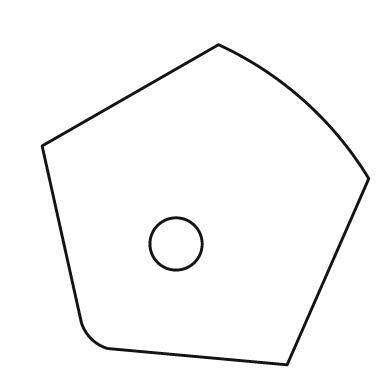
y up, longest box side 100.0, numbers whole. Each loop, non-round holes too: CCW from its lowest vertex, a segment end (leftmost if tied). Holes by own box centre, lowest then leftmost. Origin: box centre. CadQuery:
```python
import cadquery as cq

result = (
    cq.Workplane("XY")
    .moveTo(25.0, -49.0)
    .lineTo(50.0, 8.0)
    .threePointArc((30.0, 32.0), (4.0, 49.0))
    .lineTo(-50.0, 18.0)
    .lineTo(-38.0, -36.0)
    .threePointArc((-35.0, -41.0), (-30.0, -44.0))
    .close()
    .moveTo(-9.0, -12.0)
    .circle(8.0)
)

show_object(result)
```